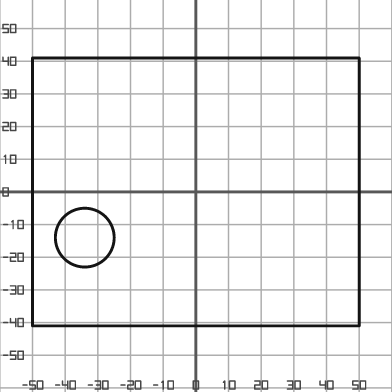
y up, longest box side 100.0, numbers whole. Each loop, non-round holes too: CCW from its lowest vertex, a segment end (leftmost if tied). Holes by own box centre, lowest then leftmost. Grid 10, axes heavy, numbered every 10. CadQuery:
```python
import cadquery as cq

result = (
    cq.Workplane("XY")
    .moveTo(-50.0, -41.0)
    .lineTo(50.0, -41.0)
    .lineTo(50.0, 41.0)
    .lineTo(-50.0, 41.0)
    .close()
    .moveTo(-34.0, -14.0)
    .circle(9.0)
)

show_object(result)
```